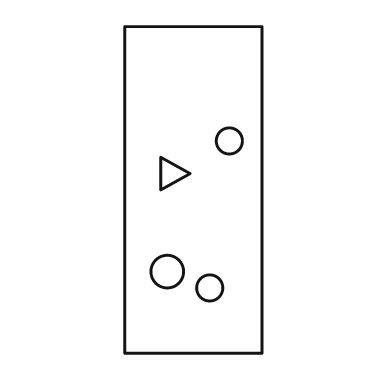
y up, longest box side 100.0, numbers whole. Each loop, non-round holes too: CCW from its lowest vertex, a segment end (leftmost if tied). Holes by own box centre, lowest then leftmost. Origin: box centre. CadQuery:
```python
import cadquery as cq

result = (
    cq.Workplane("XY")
    .moveTo(-21.0, -50.0)
    .lineTo(21.0, -50.0)
    .lineTo(21.0, 50.0)
    .lineTo(-21.0, 50.0)
    .close()
    .moveTo(5.0, -30.0)
    .circle(4.0)
    .moveTo(-8.0, -25.0)
    .circle(5.0)
    .moveTo(-10.0, 0.0)
    .lineTo(-1.0, 5.0)
    .lineTo(-10.0, 10.0)
    .close()
    .moveTo(11.0, 15.0)
    .circle(4.0)
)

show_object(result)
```